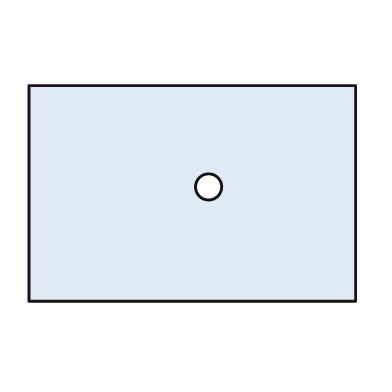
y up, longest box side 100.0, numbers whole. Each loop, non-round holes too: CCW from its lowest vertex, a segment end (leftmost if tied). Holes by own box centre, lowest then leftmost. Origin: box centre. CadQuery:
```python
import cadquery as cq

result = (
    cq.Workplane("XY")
    .moveTo(-50.0, -33.0)
    .lineTo(50.0, -33.0)
    .lineTo(50.0, 33.0)
    .lineTo(-50.0, 33.0)
    .close()
    .moveTo(5.0, 2.0)
    .circle(4.0)
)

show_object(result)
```